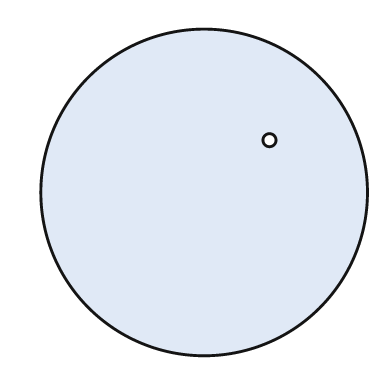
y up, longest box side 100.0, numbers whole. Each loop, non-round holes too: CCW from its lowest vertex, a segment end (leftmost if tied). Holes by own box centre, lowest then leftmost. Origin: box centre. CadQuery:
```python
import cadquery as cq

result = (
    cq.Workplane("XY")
    .moveTo(0.0, 0.0)
    .circle(50.0)
    .moveTo(20.0, 16.0)
    .circle(2.0)
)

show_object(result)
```